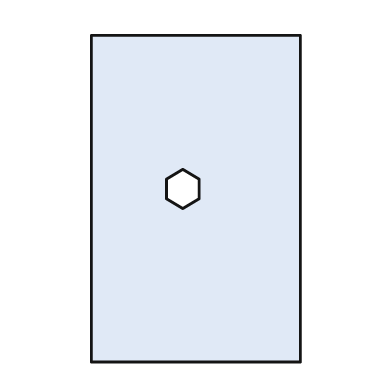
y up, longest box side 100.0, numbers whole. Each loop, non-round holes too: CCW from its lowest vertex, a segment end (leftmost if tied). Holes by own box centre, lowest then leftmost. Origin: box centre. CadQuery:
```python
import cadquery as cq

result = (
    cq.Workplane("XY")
    .moveTo(-32.0, -50.0)
    .lineTo(32.0, -50.0)
    .lineTo(32.0, 50.0)
    .lineTo(-32.0, 50.0)
    .close()
    .moveTo(-4.0, -3.0)
    .lineTo(1.0, 0.0)
    .lineTo(1.0, 6.0)
    .lineTo(-4.0, 9.0)
    .lineTo(-9.0, 6.0)
    .lineTo(-9.0, 0.0)
    .close()
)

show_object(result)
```